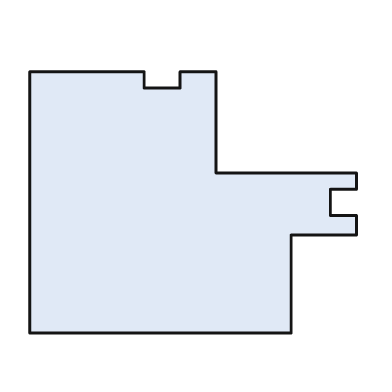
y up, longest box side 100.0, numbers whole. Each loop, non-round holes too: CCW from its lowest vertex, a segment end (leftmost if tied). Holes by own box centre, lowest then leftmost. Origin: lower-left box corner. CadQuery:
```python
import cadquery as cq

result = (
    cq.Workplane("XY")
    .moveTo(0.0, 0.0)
    .lineTo(80.0, 0.0)
    .lineTo(80.0, 30.0)
    .lineTo(100.0, 30.0)
    .lineTo(100.0, 36.0)
    .lineTo(92.0, 36.0)
    .lineTo(92.0, 44.0)
    .lineTo(100.0, 44.0)
    .lineTo(100.0, 49.0)
    .lineTo(57.0, 49.0)
    .lineTo(57.0, 80.0)
    .lineTo(46.0, 80.0)
    .lineTo(46.0, 75.0)
    .lineTo(35.0, 75.0)
    .lineTo(35.0, 80.0)
    .lineTo(0.0, 80.0)
    .close()
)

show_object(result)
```